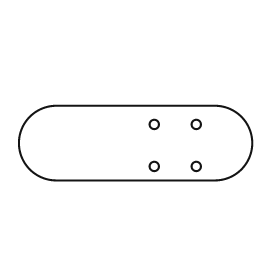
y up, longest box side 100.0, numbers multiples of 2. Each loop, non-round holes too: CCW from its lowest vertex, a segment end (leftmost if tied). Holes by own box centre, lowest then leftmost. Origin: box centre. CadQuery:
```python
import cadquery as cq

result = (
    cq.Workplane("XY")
    .moveTo(-34.0, -16.0)
    .lineTo(34.0, -16.0)
    .threePointArc((50.0, 0.0), (34.0, 16.0))
    .lineTo(-34.0, 16.0)
    .threePointArc((-50.0, 0.0), (-34.0, -16.0))
    .close()
    .moveTo(8.0, -10.0)
    .circle(2.0)
    .moveTo(26.0, -10.0)
    .circle(2.0)
    .moveTo(8.0, 8.0)
    .circle(2.0)
    .moveTo(26.0, 8.0)
    .circle(2.0)
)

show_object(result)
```